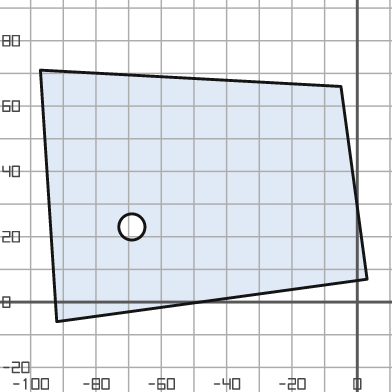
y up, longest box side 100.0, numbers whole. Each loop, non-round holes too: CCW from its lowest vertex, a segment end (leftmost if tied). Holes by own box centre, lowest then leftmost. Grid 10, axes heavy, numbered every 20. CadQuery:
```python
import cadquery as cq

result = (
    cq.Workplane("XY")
    .moveTo(-92.0, -6.0)
    .lineTo(3.0, 7.0)
    .lineTo(-5.0, 66.0)
    .lineTo(-97.0, 71.0)
    .close()
    .moveTo(-69.0, 23.0)
    .circle(4.0)
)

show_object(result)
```